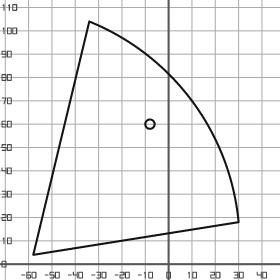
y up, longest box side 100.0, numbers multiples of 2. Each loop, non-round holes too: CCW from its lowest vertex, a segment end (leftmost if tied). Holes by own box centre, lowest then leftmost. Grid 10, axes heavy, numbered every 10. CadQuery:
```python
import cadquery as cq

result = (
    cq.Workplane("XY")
    .moveTo(-58.0, 4.0)
    .lineTo(30.0, 18.0)
    .threePointArc((10.0, 70.0), (-34.0, 104.0))
    .close()
    .moveTo(-8.0, 60.0)
    .circle(2.0)
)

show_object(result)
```